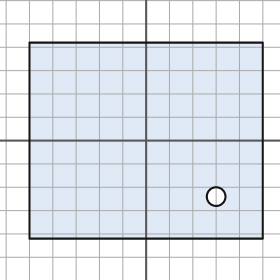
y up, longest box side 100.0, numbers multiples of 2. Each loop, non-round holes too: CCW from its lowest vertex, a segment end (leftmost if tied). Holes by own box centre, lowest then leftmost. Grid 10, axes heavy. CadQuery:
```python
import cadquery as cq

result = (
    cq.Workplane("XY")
    .moveTo(-50.0, -42.0)
    .lineTo(50.0, -42.0)
    .lineTo(50.0, 42.0)
    .lineTo(-50.0, 42.0)
    .close()
    .moveTo(30.0, -24.0)
    .circle(4.0)
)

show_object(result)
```